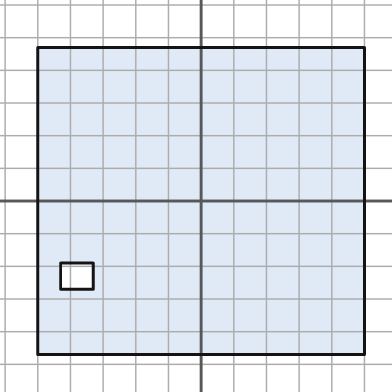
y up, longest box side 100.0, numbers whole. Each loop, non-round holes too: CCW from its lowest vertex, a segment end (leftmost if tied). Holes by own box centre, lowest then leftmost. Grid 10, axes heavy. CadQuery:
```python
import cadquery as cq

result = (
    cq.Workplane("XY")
    .moveTo(-50.0, -47.0)
    .lineTo(50.0, -47.0)
    .lineTo(50.0, 47.0)
    .lineTo(-50.0, 47.0)
    .close()
    .moveTo(-43.0, -27.0)
    .lineTo(-33.0, -27.0)
    .lineTo(-33.0, -19.0)
    .lineTo(-43.0, -19.0)
    .close()
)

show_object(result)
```